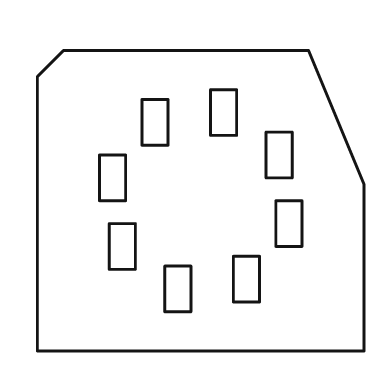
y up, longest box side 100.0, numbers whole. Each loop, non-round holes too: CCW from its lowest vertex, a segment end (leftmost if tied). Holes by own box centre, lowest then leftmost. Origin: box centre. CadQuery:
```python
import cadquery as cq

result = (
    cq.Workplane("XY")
    .moveTo(-50.0, -46.0)
    .lineTo(50.0, -46.0)
    .lineTo(50.0, 5.0)
    .lineTo(33.0, 46.0)
    .lineTo(-42.0, 46.0)
    .lineTo(-50.0, 38.0)
    .close()
    .moveTo(-11.0, -34.0)
    .lineTo(-3.0, -34.0)
    .lineTo(-3.0, -20.0)
    .lineTo(-11.0, -20.0)
    .close()
    .moveTo(10.0, -31.0)
    .lineTo(18.0, -31.0)
    .lineTo(18.0, -17.0)
    .lineTo(10.0, -17.0)
    .close()
    .moveTo(-28.0, -21.0)
    .lineTo(-20.0, -21.0)
    .lineTo(-20.0, -7.0)
    .lineTo(-28.0, -7.0)
    .close()
    .moveTo(23.0, -14.0)
    .lineTo(31.0, -14.0)
    .lineTo(31.0, 0.0)
    .lineTo(23.0, 0.0)
    .close()
    .moveTo(-31.0, 0.0)
    .lineTo(-23.0, 0.0)
    .lineTo(-23.0, 14.0)
    .lineTo(-31.0, 14.0)
    .close()
    .moveTo(20.0, 7.0)
    .lineTo(28.0, 7.0)
    .lineTo(28.0, 21.0)
    .lineTo(20.0, 21.0)
    .close()
    .moveTo(-18.0, 17.0)
    .lineTo(-10.0, 17.0)
    .lineTo(-10.0, 31.0)
    .lineTo(-18.0, 31.0)
    .close()
    .moveTo(3.0, 20.0)
    .lineTo(11.0, 20.0)
    .lineTo(11.0, 34.0)
    .lineTo(3.0, 34.0)
    .close()
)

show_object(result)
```